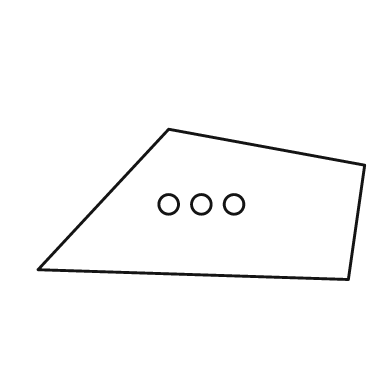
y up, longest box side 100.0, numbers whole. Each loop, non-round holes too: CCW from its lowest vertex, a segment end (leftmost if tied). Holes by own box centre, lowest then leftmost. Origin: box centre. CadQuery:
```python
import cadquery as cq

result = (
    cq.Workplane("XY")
    .moveTo(45.0, -23.0)
    .lineTo(50.0, 12.0)
    .lineTo(-10.0, 23.0)
    .lineTo(-50.0, -20.0)
    .close()
    .moveTo(-10.0, 0.0)
    .circle(3.0)
    .moveTo(0.0, 0.0)
    .circle(3.0)
    .moveTo(10.0, 0.0)
    .circle(3.0)
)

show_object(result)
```